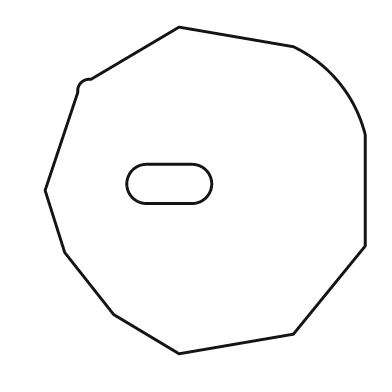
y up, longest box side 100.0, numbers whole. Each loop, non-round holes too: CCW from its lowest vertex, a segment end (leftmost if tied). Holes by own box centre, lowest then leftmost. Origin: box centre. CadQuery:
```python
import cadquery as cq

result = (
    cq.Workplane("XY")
    .moveTo(-8.0, -50.0)
    .lineTo(27.0, -44.0)
    .lineTo(49.0, -17.0)
    .lineTo(49.0, 17.0)
    .threePointArc((41.0, 33.0), (27.0, 44.0))
    .lineTo(-8.0, 50.0)
    .lineTo(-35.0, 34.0)
    .threePointArc((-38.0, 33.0), (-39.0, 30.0))
    .lineTo(-49.0, 0.0)
    .lineTo(-43.0, -19.0)
    .lineTo(-28.0, -38.0)
    .close()
    .moveTo(-18.0, -4.0)
    .lineTo(-4.0, -4.0)
    .threePointArc((2.0, 2.0), (-4.0, 8.0))
    .lineTo(-18.0, 8.0)
    .threePointArc((-24.0, 2.0), (-18.0, -4.0))
    .close()
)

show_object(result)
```